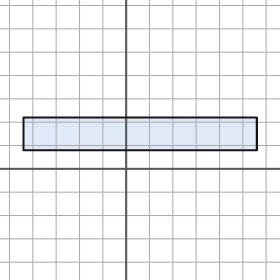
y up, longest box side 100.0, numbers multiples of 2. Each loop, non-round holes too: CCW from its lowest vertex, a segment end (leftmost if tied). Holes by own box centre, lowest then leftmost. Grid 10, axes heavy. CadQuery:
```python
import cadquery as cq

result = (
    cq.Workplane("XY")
    .moveTo(-44.0, 8.0)
    .lineTo(56.0, 8.0)
    .lineTo(56.0, 22.0)
    .lineTo(-44.0, 22.0)
    .close()
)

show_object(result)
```